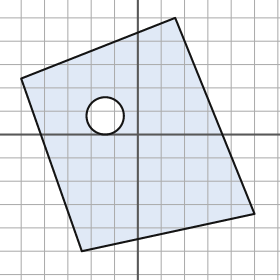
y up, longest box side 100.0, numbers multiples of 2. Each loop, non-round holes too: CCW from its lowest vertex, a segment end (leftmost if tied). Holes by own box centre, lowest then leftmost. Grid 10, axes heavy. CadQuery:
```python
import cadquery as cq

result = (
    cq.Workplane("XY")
    .moveTo(-24.0, -50.0)
    .lineTo(50.0, -34.0)
    .lineTo(16.0, 50.0)
    .lineTo(-50.0, 24.0)
    .close()
    .moveTo(-14.0, 8.0)
    .circle(8.0)
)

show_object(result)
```